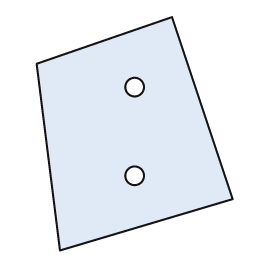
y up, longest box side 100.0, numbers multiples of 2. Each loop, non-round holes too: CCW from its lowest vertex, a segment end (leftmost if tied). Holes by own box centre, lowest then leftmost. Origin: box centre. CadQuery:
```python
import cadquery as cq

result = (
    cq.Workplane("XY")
    .moveTo(-32.0, -50.0)
    .lineTo(42.0, -28.0)
    .lineTo(16.0, 50.0)
    .lineTo(-42.0, 30.0)
    .close()
    .moveTo(0.0, -18.0)
    .circle(4.0)
    .moveTo(0.0, 20.0)
    .circle(4.0)
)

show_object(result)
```